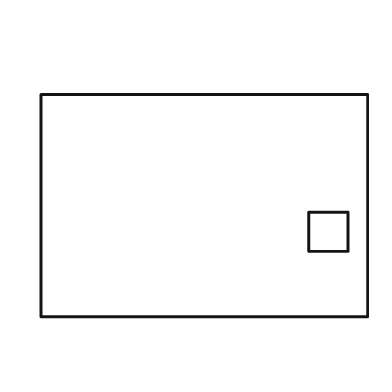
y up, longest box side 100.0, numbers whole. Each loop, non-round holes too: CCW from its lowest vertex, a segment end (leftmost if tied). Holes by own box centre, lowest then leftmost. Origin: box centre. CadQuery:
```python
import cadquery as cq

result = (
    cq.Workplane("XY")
    .moveTo(-50.0, -34.0)
    .lineTo(50.0, -34.0)
    .lineTo(50.0, 34.0)
    .lineTo(-50.0, 34.0)
    .close()
    .moveTo(32.0, -14.0)
    .lineTo(44.0, -14.0)
    .lineTo(44.0, -2.0)
    .lineTo(32.0, -2.0)
    .close()
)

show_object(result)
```